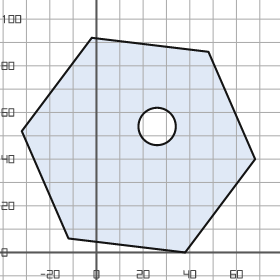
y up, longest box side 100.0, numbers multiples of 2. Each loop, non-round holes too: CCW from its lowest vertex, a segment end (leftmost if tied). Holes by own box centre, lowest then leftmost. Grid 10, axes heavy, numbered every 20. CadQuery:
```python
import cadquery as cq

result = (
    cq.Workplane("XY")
    .moveTo(38.0, 0.0)
    .lineTo(68.0, 40.0)
    .lineTo(48.0, 86.0)
    .lineTo(-2.0, 92.0)
    .lineTo(-32.0, 52.0)
    .lineTo(-12.0, 6.0)
    .close()
    .moveTo(26.0, 54.0)
    .circle(8.0)
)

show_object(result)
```